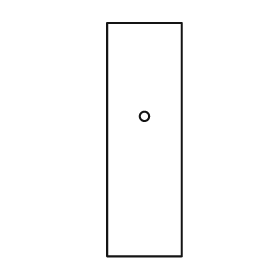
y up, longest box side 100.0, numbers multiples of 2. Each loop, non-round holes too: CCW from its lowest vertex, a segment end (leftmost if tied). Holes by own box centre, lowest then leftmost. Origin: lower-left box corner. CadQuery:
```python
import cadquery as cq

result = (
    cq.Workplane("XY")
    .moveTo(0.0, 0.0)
    .lineTo(32.0, 0.0)
    .lineTo(32.0, 100.0)
    .lineTo(0.0, 100.0)
    .close()
    .moveTo(16.0, 60.0)
    .circle(2.0)
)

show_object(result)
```